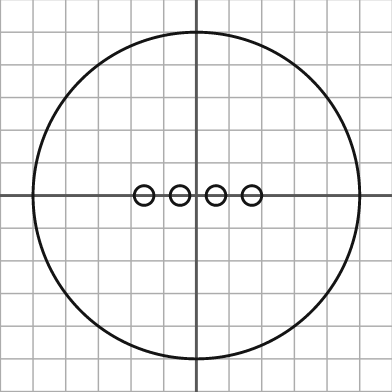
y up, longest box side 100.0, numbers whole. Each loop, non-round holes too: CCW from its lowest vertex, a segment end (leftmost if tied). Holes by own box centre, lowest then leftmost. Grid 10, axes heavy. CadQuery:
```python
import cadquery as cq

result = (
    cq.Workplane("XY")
    .moveTo(0.0, 0.0)
    .circle(50.0)
    .moveTo(-16.0, 0.0)
    .circle(3.0)
    .moveTo(-5.0, 0.0)
    .circle(3.0)
    .moveTo(6.0, 0.0)
    .circle(3.0)
    .moveTo(17.0, 0.0)
    .circle(3.0)
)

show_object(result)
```